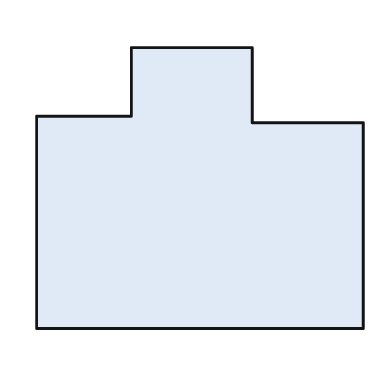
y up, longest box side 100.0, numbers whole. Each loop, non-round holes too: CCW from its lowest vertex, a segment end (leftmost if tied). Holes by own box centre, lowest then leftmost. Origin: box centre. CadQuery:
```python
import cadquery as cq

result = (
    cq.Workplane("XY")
    .moveTo(-50.0, -43.0)
    .lineTo(50.0, -43.0)
    .lineTo(50.0, 20.0)
    .lineTo(16.0, 20.0)
    .lineTo(16.0, 43.0)
    .lineTo(-21.0, 43.0)
    .lineTo(-21.0, 22.0)
    .lineTo(-50.0, 22.0)
    .close()
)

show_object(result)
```